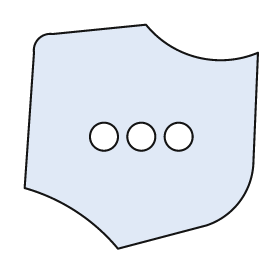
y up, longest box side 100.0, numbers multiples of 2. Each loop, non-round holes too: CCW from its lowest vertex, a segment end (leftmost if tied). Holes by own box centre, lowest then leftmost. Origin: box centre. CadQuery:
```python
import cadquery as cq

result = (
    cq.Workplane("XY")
    .moveTo(-10.0, -48.0)
    .lineTo(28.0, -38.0)
    .threePointArc((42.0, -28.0), (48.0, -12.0))
    .lineTo(50.0, 36.0)
    .threePointArc((24.0, 34.0), (2.0, 48.0))
    .lineTo(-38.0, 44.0)
    .threePointArc((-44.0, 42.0), (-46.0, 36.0))
    .lineTo(-50.0, -22.0)
    .threePointArc((-28.0, -32.0), (-10.0, -48.0))
    .close()
    .moveTo(-16.0, 0.0)
    .circle(6.0)
    .moveTo(0.0, 0.0)
    .circle(6.0)
    .moveTo(16.0, 0.0)
    .circle(6.0)
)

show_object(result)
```